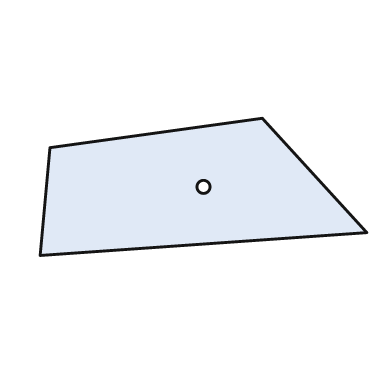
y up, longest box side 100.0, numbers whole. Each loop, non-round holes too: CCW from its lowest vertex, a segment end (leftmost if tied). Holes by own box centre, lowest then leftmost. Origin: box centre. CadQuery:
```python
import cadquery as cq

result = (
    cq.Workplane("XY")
    .moveTo(-50.0, -21.0)
    .lineTo(50.0, -14.0)
    .lineTo(18.0, 21.0)
    .lineTo(-47.0, 12.0)
    .close()
    .moveTo(0.0, 0.0)
    .circle(2.0)
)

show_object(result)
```